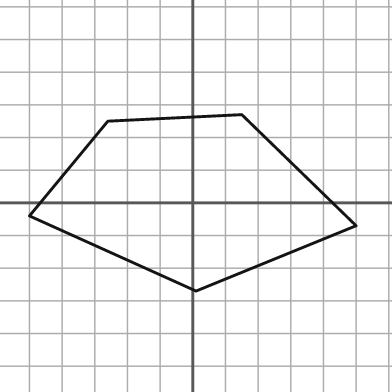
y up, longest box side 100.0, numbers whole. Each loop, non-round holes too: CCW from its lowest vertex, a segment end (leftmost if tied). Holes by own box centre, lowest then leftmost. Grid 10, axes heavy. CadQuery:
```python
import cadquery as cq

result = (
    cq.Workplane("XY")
    .moveTo(1.0, -27.0)
    .lineTo(50.0, -7.0)
    .lineTo(15.0, 27.0)
    .lineTo(-26.0, 25.0)
    .lineTo(-50.0, -4.0)
    .close()
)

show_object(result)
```